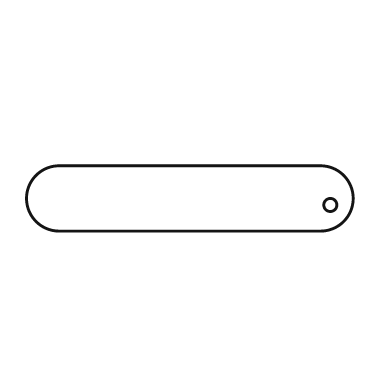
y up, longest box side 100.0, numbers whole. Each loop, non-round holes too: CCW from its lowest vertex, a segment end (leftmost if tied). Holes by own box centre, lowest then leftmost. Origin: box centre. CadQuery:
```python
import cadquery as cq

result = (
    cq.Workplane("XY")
    .moveTo(-40.0, -10.0)
    .lineTo(40.0, -10.0)
    .threePointArc((50.0, 0.0), (40.0, 10.0))
    .lineTo(-40.0, 10.0)
    .threePointArc((-50.0, 0.0), (-40.0, -10.0))
    .close()
    .moveTo(43.0, -2.0)
    .circle(2.0)
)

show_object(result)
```